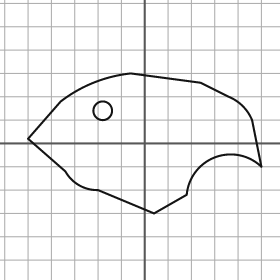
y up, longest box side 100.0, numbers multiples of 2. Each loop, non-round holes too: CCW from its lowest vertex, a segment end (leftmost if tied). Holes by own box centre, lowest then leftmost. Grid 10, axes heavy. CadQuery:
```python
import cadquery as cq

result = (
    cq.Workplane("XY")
    .moveTo(4.0, -30.0)
    .lineTo(18.0, -22.0)
    .threePointArc((30.0, -6.0), (50.0, -10.0))
    .lineTo(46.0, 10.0)
    .threePointArc((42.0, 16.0), (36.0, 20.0))
    .lineTo(24.0, 26.0)
    .lineTo(-6.0, 30.0)
    .threePointArc((-22.0, 26.0), (-36.0, 18.0))
    .lineTo(-50.0, 2.0)
    .lineTo(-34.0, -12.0)
    .threePointArc((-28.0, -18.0), (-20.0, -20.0))
    .close()
    .moveTo(-18.0, 14.0)
    .circle(4.0)
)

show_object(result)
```